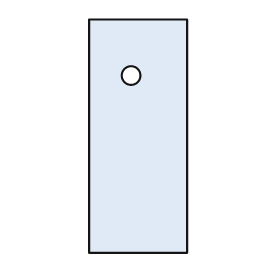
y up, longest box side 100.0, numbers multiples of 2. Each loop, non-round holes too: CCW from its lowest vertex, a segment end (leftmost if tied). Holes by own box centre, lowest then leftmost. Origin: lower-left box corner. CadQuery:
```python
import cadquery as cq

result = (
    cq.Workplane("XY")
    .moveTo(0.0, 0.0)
    .lineTo(42.0, 0.0)
    .lineTo(42.0, 100.0)
    .lineTo(0.0, 100.0)
    .close()
    .moveTo(18.0, 76.0)
    .circle(4.0)
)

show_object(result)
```